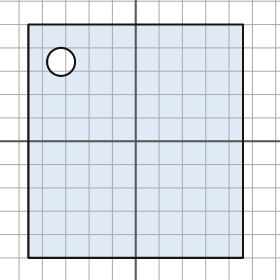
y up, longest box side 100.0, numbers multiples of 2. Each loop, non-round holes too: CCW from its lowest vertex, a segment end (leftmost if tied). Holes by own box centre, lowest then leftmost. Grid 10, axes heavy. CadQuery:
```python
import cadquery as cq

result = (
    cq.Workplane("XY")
    .moveTo(-46.0, -50.0)
    .lineTo(46.0, -50.0)
    .lineTo(46.0, 50.0)
    .lineTo(-46.0, 50.0)
    .close()
    .moveTo(-32.0, 34.0)
    .circle(6.0)
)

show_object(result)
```